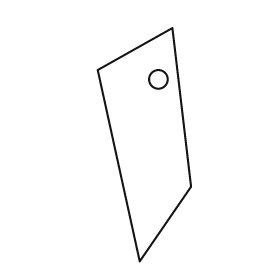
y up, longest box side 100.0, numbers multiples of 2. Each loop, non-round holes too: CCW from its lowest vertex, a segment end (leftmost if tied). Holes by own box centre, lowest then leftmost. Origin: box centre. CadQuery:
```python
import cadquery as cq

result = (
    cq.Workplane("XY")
    .moveTo(-2.0, -50.0)
    .lineTo(20.0, -18.0)
    .lineTo(12.0, 50.0)
    .lineTo(-20.0, 32.0)
    .close()
    .moveTo(6.0, 28.0)
    .circle(4.0)
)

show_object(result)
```